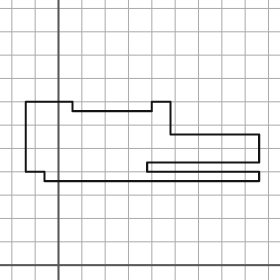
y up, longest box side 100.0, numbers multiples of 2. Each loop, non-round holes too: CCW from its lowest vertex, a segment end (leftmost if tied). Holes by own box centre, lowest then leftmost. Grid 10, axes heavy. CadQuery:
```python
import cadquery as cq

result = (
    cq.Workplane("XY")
    .moveTo(-6.0, 36.0)
    .lineTo(86.0, 36.0)
    .lineTo(86.0, 40.0)
    .lineTo(38.0, 40.0)
    .lineTo(38.0, 44.0)
    .lineTo(86.0, 44.0)
    .lineTo(86.0, 56.0)
    .lineTo(48.0, 56.0)
    .lineTo(48.0, 70.0)
    .lineTo(40.0, 70.0)
    .lineTo(40.0, 66.0)
    .lineTo(6.0, 66.0)
    .lineTo(6.0, 70.0)
    .lineTo(-14.0, 70.0)
    .lineTo(-14.0, 40.0)
    .lineTo(-6.0, 40.0)
    .close()
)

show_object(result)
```